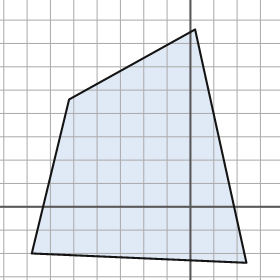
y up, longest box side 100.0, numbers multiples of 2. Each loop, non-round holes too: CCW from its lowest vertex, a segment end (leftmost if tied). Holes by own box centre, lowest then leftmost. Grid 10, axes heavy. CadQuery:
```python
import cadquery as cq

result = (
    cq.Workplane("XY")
    .moveTo(24.0, -24.0)
    .lineTo(2.0, 76.0)
    .lineTo(-52.0, 46.0)
    .lineTo(-68.0, -20.0)
    .close()
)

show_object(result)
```